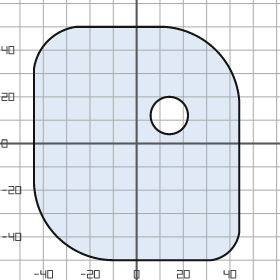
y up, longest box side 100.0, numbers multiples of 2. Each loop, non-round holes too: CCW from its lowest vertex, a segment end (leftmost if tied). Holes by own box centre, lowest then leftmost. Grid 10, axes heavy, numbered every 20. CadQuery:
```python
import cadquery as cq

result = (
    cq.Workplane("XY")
    .moveTo(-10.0, -50.0)
    .lineTo(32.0, -50.0)
    .threePointArc((40.0, -46.0), (44.0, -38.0))
    .lineTo(44.0, 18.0)
    .threePointArc((34.0, 40.0), (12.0, 50.0))
    .lineTo(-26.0, 50.0)
    .threePointArc((-38.0, 44.0), (-44.0, 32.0))
    .lineTo(-44.0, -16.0)
    .threePointArc((-34.0, -40.0), (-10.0, -50.0))
    .close()
    .moveTo(14.0, 12.0)
    .circle(8.0)
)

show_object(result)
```